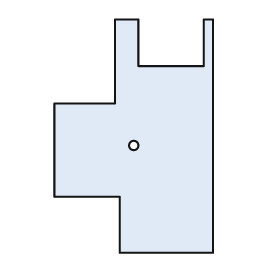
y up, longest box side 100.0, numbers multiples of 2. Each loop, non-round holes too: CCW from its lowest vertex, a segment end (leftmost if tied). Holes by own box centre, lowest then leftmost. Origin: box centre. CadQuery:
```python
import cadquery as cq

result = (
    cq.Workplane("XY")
    .moveTo(-6.0, -50.0)
    .lineTo(34.0, -50.0)
    .lineTo(34.0, 50.0)
    .lineTo(30.0, 50.0)
    .lineTo(30.0, 30.0)
    .lineTo(2.0, 30.0)
    .lineTo(2.0, 50.0)
    .lineTo(-8.0, 50.0)
    .lineTo(-8.0, 14.0)
    .lineTo(-34.0, 14.0)
    .lineTo(-34.0, -26.0)
    .lineTo(-6.0, -26.0)
    .close()
    .moveTo(0.0, -4.0)
    .circle(2.0)
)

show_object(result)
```